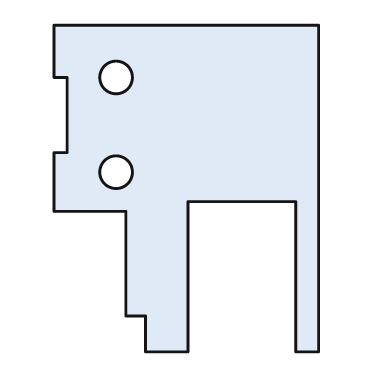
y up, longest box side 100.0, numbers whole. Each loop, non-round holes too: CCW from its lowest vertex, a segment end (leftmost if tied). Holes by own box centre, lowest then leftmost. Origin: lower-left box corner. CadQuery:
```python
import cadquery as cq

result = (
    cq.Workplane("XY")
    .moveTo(28.0, 0.0)
    .lineTo(41.0, 0.0)
    .lineTo(41.0, 46.0)
    .lineTo(74.0, 46.0)
    .lineTo(74.0, 0.0)
    .lineTo(81.0, 0.0)
    .lineTo(81.0, 100.0)
    .lineTo(0.0, 100.0)
    .lineTo(0.0, 84.0)
    .lineTo(4.0, 84.0)
    .lineTo(4.0, 61.0)
    .lineTo(0.0, 61.0)
    .lineTo(0.0, 43.0)
    .lineTo(22.0, 43.0)
    .lineTo(22.0, 11.0)
    .lineTo(28.0, 11.0)
    .close()
    .moveTo(19.0, 55.0)
    .circle(5.0)
    .moveTo(19.0, 84.0)
    .circle(5.0)
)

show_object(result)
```